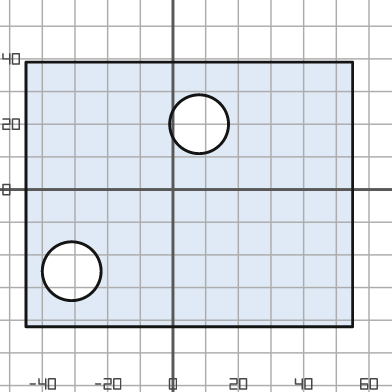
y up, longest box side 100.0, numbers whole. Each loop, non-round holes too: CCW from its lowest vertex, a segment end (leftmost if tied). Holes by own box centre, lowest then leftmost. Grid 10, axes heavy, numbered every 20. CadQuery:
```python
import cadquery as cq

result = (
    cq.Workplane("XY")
    .moveTo(-45.0, -42.0)
    .lineTo(55.0, -42.0)
    .lineTo(55.0, 39.0)
    .lineTo(-45.0, 39.0)
    .close()
    .moveTo(-31.0, -25.0)
    .circle(9.0)
    .moveTo(8.0, 20.0)
    .circle(9.0)
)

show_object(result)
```